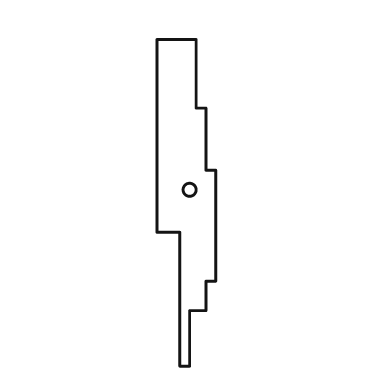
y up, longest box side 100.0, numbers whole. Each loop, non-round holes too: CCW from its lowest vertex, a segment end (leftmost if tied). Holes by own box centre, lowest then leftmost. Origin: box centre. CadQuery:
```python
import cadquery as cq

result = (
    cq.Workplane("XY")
    .moveTo(-2.0, -50.0)
    .lineTo(1.0, -50.0)
    .lineTo(1.0, -33.0)
    .lineTo(6.0, -33.0)
    .lineTo(6.0, -24.0)
    .lineTo(9.0, -24.0)
    .lineTo(9.0, 10.0)
    .lineTo(6.0, 10.0)
    .lineTo(6.0, 29.0)
    .lineTo(3.0, 29.0)
    .lineTo(3.0, 50.0)
    .lineTo(-9.0, 50.0)
    .lineTo(-9.0, -9.0)
    .lineTo(-2.0, -9.0)
    .close()
    .moveTo(1.0, 4.0)
    .circle(2.0)
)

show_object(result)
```